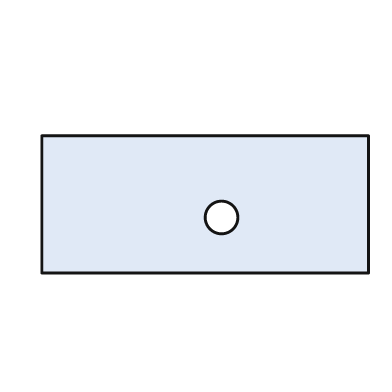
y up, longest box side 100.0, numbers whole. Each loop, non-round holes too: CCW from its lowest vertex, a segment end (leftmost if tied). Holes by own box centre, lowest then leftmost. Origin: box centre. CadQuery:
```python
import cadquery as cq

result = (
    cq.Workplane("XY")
    .moveTo(-50.0, -21.0)
    .lineTo(50.0, -21.0)
    .lineTo(50.0, 21.0)
    .lineTo(-50.0, 21.0)
    .close()
    .moveTo(5.0, -4.0)
    .circle(5.0)
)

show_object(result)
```